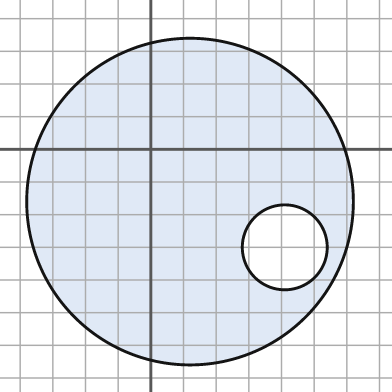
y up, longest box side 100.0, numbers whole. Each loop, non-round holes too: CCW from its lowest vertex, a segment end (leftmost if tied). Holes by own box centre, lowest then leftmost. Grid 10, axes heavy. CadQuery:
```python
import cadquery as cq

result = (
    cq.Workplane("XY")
    .moveTo(12.0, -16.0)
    .circle(50.0)
    .moveTo(41.0, -30.0)
    .circle(13.0)
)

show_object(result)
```